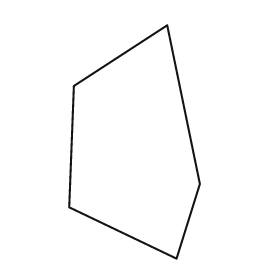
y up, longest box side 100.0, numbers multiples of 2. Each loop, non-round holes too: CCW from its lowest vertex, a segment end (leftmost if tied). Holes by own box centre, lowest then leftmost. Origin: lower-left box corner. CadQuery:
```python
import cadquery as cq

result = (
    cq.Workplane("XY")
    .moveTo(46.0, 0.0)
    .lineTo(56.0, 32.0)
    .lineTo(42.0, 100.0)
    .lineTo(2.0, 74.0)
    .lineTo(0.0, 22.0)
    .close()
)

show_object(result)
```